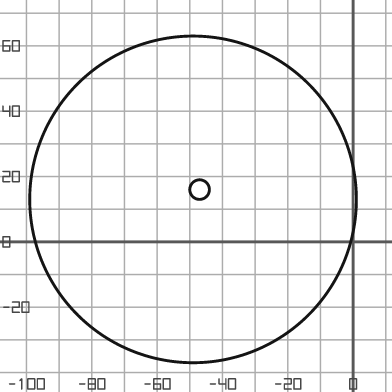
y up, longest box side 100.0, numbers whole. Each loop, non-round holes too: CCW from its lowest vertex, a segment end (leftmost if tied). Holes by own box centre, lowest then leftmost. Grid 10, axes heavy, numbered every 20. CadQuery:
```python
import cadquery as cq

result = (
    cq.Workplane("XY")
    .moveTo(-49.0, 13.0)
    .circle(50.0)
    .moveTo(-47.0, 16.0)
    .circle(3.0)
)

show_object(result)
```